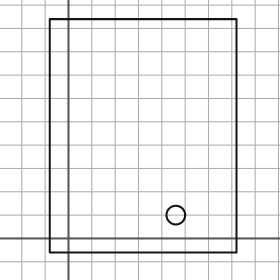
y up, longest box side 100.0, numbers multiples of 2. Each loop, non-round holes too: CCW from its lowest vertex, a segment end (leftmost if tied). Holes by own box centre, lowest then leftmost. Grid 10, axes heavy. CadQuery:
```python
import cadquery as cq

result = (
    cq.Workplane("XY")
    .moveTo(-8.0, -6.0)
    .lineTo(72.0, -6.0)
    .lineTo(72.0, 94.0)
    .lineTo(-8.0, 94.0)
    .close()
    .moveTo(46.0, 10.0)
    .circle(4.0)
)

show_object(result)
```